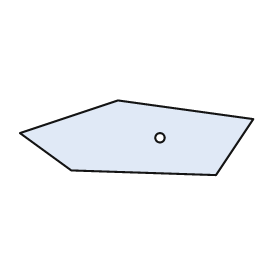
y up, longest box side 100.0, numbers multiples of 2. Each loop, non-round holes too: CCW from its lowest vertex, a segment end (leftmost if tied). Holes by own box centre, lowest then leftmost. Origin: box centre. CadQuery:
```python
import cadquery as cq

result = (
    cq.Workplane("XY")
    .moveTo(34.0, -16.0)
    .lineTo(50.0, 8.0)
    .lineTo(-8.0, 16.0)
    .lineTo(-50.0, 2.0)
    .lineTo(-28.0, -14.0)
    .close()
    .moveTo(10.0, 0.0)
    .circle(2.0)
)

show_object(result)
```